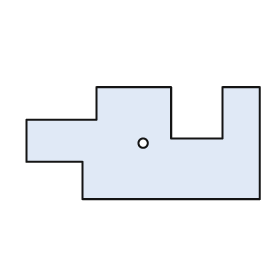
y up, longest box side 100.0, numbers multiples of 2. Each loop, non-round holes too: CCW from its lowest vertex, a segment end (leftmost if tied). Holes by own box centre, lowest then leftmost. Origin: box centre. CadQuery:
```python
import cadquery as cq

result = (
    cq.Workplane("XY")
    .moveTo(-26.0, -24.0)
    .lineTo(50.0, -24.0)
    .lineTo(50.0, 24.0)
    .lineTo(34.0, 24.0)
    .lineTo(34.0, 2.0)
    .lineTo(12.0, 2.0)
    .lineTo(12.0, 24.0)
    .lineTo(-20.0, 24.0)
    .lineTo(-20.0, 10.0)
    .lineTo(-50.0, 10.0)
    .lineTo(-50.0, -8.0)
    .lineTo(-26.0, -8.0)
    .close()
    .moveTo(0.0, 0.0)
    .circle(2.0)
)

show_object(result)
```